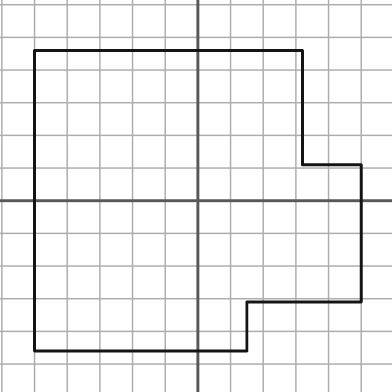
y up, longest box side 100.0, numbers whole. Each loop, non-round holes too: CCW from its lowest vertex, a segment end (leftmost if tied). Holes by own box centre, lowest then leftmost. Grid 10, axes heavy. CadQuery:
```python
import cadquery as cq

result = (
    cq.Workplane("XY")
    .moveTo(-50.0, -46.0)
    .lineTo(15.0, -46.0)
    .lineTo(15.0, -31.0)
    .lineTo(50.0, -31.0)
    .lineTo(50.0, 11.0)
    .lineTo(32.0, 11.0)
    .lineTo(32.0, 46.0)
    .lineTo(-50.0, 46.0)
    .close()
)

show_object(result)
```